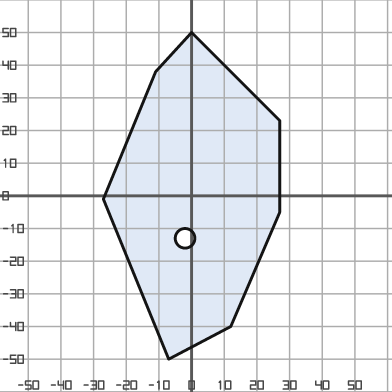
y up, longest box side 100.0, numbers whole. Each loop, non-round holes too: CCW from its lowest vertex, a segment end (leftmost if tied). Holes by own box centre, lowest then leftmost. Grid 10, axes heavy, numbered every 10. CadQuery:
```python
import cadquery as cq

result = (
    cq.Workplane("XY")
    .moveTo(-7.0, -50.0)
    .lineTo(12.0, -40.0)
    .lineTo(27.0, -5.0)
    .lineTo(27.0, 23.0)
    .lineTo(0.0, 50.0)
    .lineTo(-11.0, 38.0)
    .lineTo(-27.0, -1.0)
    .close()
    .moveTo(-2.0, -13.0)
    .circle(3.0)
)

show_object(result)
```